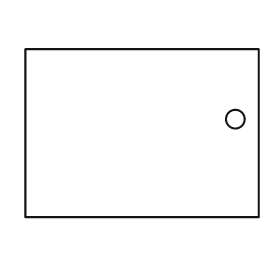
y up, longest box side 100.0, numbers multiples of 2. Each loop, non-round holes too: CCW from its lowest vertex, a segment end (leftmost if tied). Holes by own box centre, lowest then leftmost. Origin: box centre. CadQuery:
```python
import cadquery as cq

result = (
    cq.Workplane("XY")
    .moveTo(-50.0, -36.0)
    .lineTo(50.0, -36.0)
    .lineTo(50.0, 36.0)
    .lineTo(-50.0, 36.0)
    .close()
    .moveTo(40.0, 6.0)
    .circle(4.0)
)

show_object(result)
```